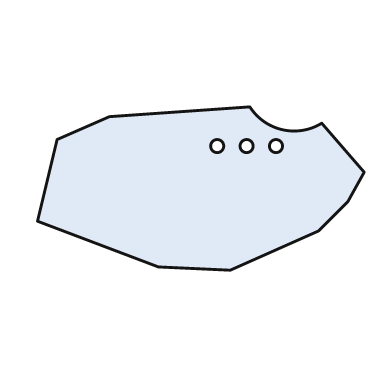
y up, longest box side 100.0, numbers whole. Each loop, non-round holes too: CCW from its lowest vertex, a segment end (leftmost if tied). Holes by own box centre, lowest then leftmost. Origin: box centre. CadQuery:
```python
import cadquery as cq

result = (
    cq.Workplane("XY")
    .moveTo(9.0, -25.0)
    .lineTo(36.0, -13.0)
    .lineTo(45.0, -4.0)
    .lineTo(50.0, 5.0)
    .lineTo(37.0, 20.0)
    .threePointArc((25.0, 18.0), (15.0, 25.0))
    .lineTo(-28.0, 22.0)
    .lineTo(-44.0, 15.0)
    .lineTo(-50.0, -10.0)
    .lineTo(-13.0, -24.0)
    .close()
    .moveTo(5.0, 13.0)
    .circle(2.0)
    .moveTo(14.0, 13.0)
    .circle(2.0)
    .moveTo(23.0, 13.0)
    .circle(2.0)
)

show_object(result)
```